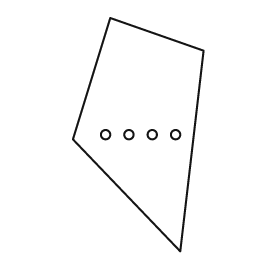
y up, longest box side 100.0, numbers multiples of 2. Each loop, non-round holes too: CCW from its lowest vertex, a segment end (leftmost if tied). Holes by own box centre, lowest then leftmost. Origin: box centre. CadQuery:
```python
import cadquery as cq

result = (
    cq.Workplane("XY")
    .moveTo(18.0, -50.0)
    .lineTo(28.0, 36.0)
    .lineTo(-12.0, 50.0)
    .lineTo(-28.0, -2.0)
    .close()
    .moveTo(-14.0, 0.0)
    .circle(2.0)
    .moveTo(-4.0, 0.0)
    .circle(2.0)
    .moveTo(6.0, 0.0)
    .circle(2.0)
    .moveTo(16.0, 0.0)
    .circle(2.0)
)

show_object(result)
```